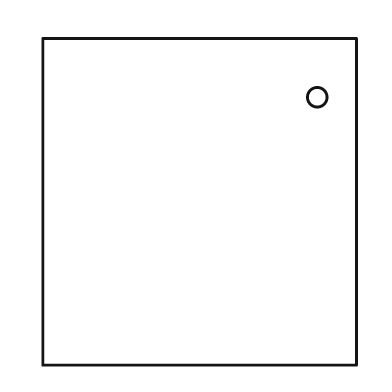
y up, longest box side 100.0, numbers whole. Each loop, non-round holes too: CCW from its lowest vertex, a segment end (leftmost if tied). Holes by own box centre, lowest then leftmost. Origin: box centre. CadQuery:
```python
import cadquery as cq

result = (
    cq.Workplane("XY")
    .moveTo(-48.0, -50.0)
    .lineTo(48.0, -50.0)
    .lineTo(48.0, 50.0)
    .lineTo(-48.0, 50.0)
    .close()
    .moveTo(36.0, 32.0)
    .circle(3.0)
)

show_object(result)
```